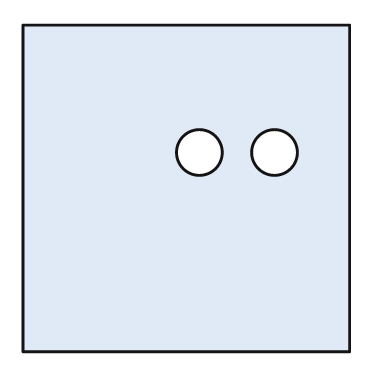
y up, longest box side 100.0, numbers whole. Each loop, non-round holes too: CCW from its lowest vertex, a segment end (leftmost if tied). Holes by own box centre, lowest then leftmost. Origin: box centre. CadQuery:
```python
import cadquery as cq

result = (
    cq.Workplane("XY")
    .moveTo(-50.0, -50.0)
    .lineTo(50.0, -50.0)
    .lineTo(50.0, 50.0)
    .lineTo(-50.0, 50.0)
    .close()
    .moveTo(4.0, 11.0)
    .circle(7.0)
    .moveTo(27.0, 11.0)
    .circle(7.0)
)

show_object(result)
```